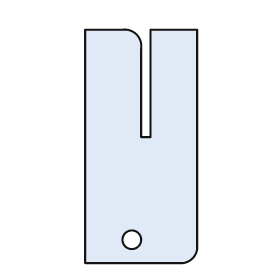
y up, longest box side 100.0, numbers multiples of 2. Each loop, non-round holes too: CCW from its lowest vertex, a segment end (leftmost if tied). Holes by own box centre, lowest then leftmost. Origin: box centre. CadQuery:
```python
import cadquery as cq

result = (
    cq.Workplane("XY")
    .moveTo(-24.0, -50.0)
    .lineTo(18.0, -50.0)
    .threePointArc((22.0, -48.0), (24.0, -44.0))
    .lineTo(24.0, 50.0)
    .lineTo(4.0, 50.0)
    .lineTo(4.0, 4.0)
    .lineTo(0.0, 4.0)
    .lineTo(0.0, 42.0)
    .threePointArc((-2.0, 48.0), (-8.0, 50.0))
    .lineTo(-24.0, 50.0)
    .close()
    .moveTo(-4.0, -40.0)
    .circle(4.0)
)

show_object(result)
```